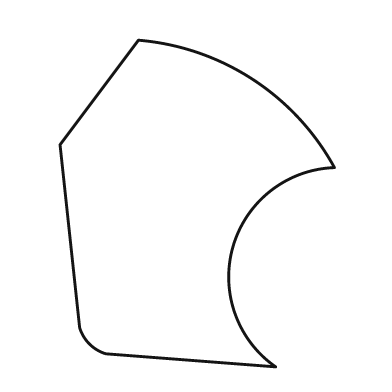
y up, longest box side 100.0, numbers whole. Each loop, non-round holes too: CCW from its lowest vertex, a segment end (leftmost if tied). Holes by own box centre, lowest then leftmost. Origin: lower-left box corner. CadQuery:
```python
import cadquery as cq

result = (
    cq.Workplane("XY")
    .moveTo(66.0, 0.0)
    .threePointArc((53.0, 37.0), (84.0, 61.0))
    .threePointArc((59.0, 88.0), (24.0, 100.0))
    .lineTo(0.0, 68.0)
    .lineTo(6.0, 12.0)
    .threePointArc((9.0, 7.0), (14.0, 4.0))
    .close()
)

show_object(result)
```